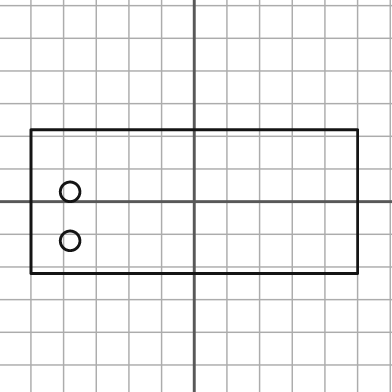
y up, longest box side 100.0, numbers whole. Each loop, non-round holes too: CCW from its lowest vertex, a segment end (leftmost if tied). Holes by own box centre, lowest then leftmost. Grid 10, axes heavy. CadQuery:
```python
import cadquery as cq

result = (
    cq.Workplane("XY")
    .moveTo(-50.0, -22.0)
    .lineTo(50.0, -22.0)
    .lineTo(50.0, 22.0)
    .lineTo(-50.0, 22.0)
    .close()
    .moveTo(-38.0, -12.0)
    .circle(3.0)
    .moveTo(-38.0, 3.0)
    .circle(3.0)
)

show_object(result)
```